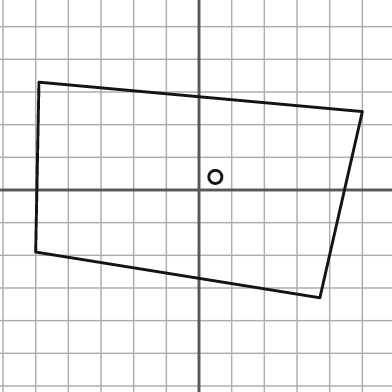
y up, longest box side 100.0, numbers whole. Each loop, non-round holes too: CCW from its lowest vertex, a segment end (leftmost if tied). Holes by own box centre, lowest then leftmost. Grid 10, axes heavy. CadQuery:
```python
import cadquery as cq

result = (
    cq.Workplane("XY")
    .moveTo(37.0, -33.0)
    .lineTo(50.0, 24.0)
    .lineTo(-49.0, 33.0)
    .lineTo(-50.0, -19.0)
    .close()
    .moveTo(5.0, 4.0)
    .circle(2.0)
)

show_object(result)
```